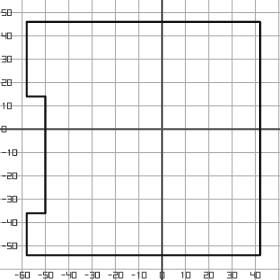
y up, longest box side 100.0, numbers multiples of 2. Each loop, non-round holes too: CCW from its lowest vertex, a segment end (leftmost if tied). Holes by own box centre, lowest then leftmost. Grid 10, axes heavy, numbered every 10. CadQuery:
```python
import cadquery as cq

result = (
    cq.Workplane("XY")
    .moveTo(-58.0, -54.0)
    .lineTo(42.0, -54.0)
    .lineTo(42.0, 46.0)
    .lineTo(-58.0, 46.0)
    .lineTo(-58.0, 14.0)
    .lineTo(-50.0, 14.0)
    .lineTo(-50.0, -36.0)
    .lineTo(-58.0, -36.0)
    .close()
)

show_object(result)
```